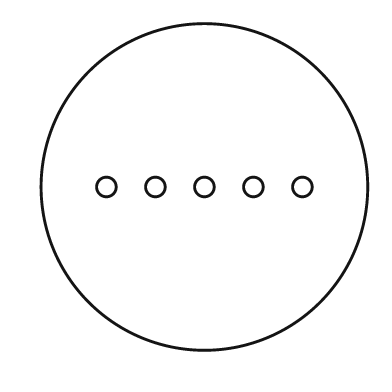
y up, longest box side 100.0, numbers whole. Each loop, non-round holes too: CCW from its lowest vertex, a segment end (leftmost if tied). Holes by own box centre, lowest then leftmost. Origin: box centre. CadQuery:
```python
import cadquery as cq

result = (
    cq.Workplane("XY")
    .moveTo(0.0, 0.0)
    .circle(50.0)
    .moveTo(-30.0, 0.0)
    .circle(3.0)
    .moveTo(-15.0, 0.0)
    .circle(3.0)
    .moveTo(0.0, 0.0)
    .circle(3.0)
    .moveTo(15.0, 0.0)
    .circle(3.0)
    .moveTo(30.0, 0.0)
    .circle(3.0)
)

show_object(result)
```